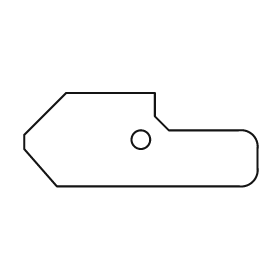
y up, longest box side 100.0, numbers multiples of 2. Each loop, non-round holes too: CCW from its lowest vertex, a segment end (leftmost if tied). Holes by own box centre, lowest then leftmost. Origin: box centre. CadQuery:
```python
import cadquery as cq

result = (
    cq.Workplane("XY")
    .moveTo(-36.0, -20.0)
    .lineTo(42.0, -20.0)
    .threePointArc((48.0, -18.0), (50.0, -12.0))
    .lineTo(50.0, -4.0)
    .threePointArc((48.0, 2.0), (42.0, 4.0))
    .lineTo(12.0, 4.0)
    .lineTo(6.0, 10.0)
    .lineTo(6.0, 20.0)
    .lineTo(-32.0, 20.0)
    .lineTo(-50.0, 2.0)
    .lineTo(-50.0, -4.0)
    .close()
    .moveTo(0.0, 0.0)
    .circle(4.0)
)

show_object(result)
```